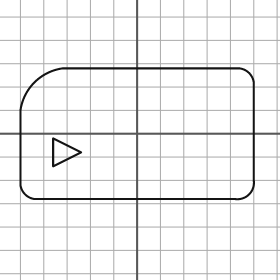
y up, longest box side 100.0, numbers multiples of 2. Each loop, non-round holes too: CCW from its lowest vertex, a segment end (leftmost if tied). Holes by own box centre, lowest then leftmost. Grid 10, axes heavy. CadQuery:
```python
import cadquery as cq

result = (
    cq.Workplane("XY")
    .moveTo(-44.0, -28.0)
    .lineTo(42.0, -28.0)
    .threePointArc((48.0, -26.0), (50.0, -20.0))
    .lineTo(50.0, 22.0)
    .threePointArc((48.0, 26.0), (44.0, 28.0))
    .lineTo(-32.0, 28.0)
    .threePointArc((-44.0, 22.0), (-50.0, 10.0))
    .lineTo(-50.0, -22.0)
    .threePointArc((-48.0, -26.0), (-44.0, -28.0))
    .close()
    .moveTo(-36.0, -14.0)
    .lineTo(-24.0, -8.0)
    .lineTo(-36.0, -2.0)
    .close()
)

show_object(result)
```